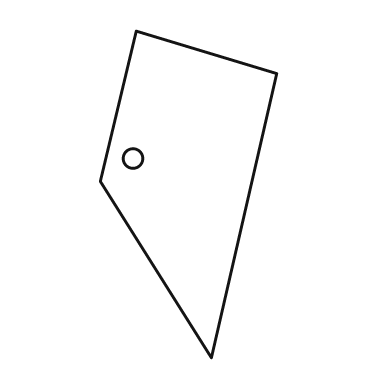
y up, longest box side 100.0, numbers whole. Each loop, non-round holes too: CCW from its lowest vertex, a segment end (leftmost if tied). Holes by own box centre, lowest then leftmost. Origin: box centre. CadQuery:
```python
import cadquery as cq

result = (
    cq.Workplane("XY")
    .moveTo(7.0, -50.0)
    .lineTo(27.0, 37.0)
    .lineTo(-16.0, 50.0)
    .lineTo(-27.0, 4.0)
    .close()
    .moveTo(-17.0, 11.0)
    .circle(3.0)
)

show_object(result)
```